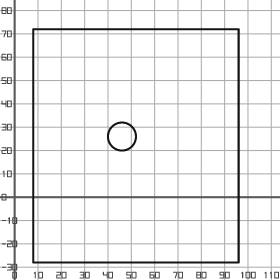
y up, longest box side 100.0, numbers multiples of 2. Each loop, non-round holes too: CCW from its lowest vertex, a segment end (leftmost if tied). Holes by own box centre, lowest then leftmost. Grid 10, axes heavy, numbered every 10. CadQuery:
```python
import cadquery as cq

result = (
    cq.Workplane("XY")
    .moveTo(8.0, -28.0)
    .lineTo(96.0, -28.0)
    .lineTo(96.0, 72.0)
    .lineTo(8.0, 72.0)
    .close()
    .moveTo(46.0, 26.0)
    .circle(6.0)
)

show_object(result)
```